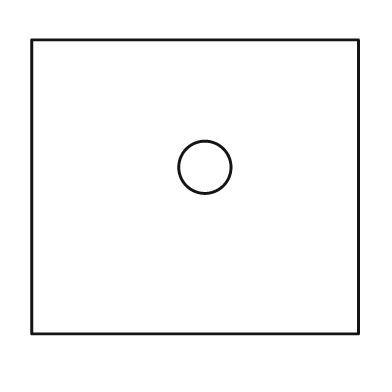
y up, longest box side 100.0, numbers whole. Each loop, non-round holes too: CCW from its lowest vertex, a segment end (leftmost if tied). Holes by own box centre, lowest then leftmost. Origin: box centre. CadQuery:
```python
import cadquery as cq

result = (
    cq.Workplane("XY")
    .moveTo(-50.0, -45.0)
    .lineTo(50.0, -45.0)
    .lineTo(50.0, 45.0)
    .lineTo(-50.0, 45.0)
    .close()
    .moveTo(3.0, 6.0)
    .circle(8.0)
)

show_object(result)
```